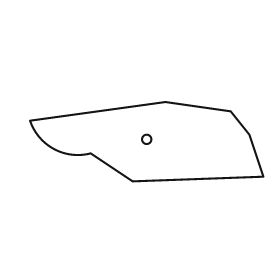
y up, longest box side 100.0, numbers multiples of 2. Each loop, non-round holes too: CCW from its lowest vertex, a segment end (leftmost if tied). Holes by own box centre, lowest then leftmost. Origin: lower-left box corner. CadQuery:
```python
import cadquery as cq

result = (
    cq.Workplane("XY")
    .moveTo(44.0, 0.0)
    .lineTo(100.0, 2.0)
    .lineTo(94.0, 20.0)
    .lineTo(86.0, 30.0)
    .lineTo(58.0, 34.0)
    .lineTo(0.0, 26.0)
    .threePointArc((10.0, 14.0), (26.0, 12.0))
    .close()
    .moveTo(50.0, 18.0)
    .circle(2.0)
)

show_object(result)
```